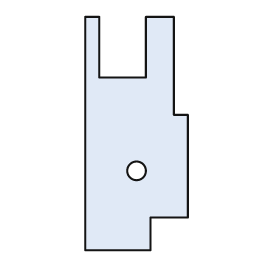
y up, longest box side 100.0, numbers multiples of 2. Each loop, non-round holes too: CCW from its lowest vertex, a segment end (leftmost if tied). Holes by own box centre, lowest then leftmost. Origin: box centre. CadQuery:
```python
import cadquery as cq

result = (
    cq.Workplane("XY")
    .moveTo(-22.0, -50.0)
    .lineTo(6.0, -50.0)
    .lineTo(6.0, -36.0)
    .lineTo(22.0, -36.0)
    .lineTo(22.0, 8.0)
    .lineTo(16.0, 8.0)
    .lineTo(16.0, 50.0)
    .lineTo(4.0, 50.0)
    .lineTo(4.0, 24.0)
    .lineTo(-16.0, 24.0)
    .lineTo(-16.0, 50.0)
    .lineTo(-22.0, 50.0)
    .close()
    .moveTo(0.0, -16.0)
    .circle(4.0)
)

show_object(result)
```